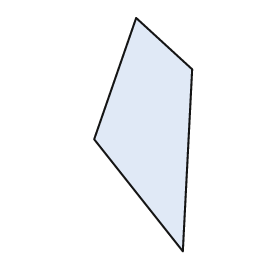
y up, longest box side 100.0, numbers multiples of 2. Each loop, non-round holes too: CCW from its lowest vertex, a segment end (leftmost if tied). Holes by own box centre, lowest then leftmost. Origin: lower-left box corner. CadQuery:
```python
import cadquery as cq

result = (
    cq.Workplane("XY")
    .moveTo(38.0, 0.0)
    .lineTo(42.0, 78.0)
    .lineTo(18.0, 100.0)
    .lineTo(0.0, 48.0)
    .close()
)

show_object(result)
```